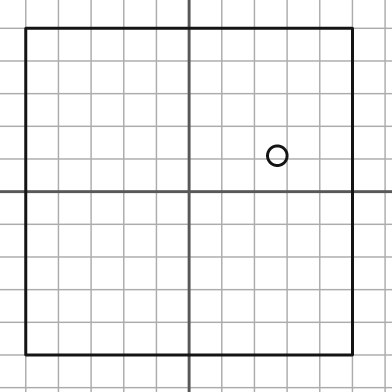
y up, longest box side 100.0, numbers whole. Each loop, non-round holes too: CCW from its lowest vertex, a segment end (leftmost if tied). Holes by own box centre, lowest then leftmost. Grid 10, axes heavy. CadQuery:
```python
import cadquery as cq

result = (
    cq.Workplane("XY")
    .moveTo(-50.0, -50.0)
    .lineTo(50.0, -50.0)
    .lineTo(50.0, 50.0)
    .lineTo(-50.0, 50.0)
    .close()
    .moveTo(27.0, 11.0)
    .circle(3.0)
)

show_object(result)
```